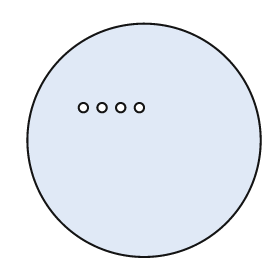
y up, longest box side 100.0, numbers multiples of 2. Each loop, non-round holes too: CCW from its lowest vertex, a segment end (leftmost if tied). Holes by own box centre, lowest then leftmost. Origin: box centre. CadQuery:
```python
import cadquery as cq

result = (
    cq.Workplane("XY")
    .moveTo(0.0, 0.0)
    .circle(50.0)
    .moveTo(-26.0, 14.0)
    .circle(2.0)
    .moveTo(-18.0, 14.0)
    .circle(2.0)
    .moveTo(-10.0, 14.0)
    .circle(2.0)
    .moveTo(-2.0, 14.0)
    .circle(2.0)
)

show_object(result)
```